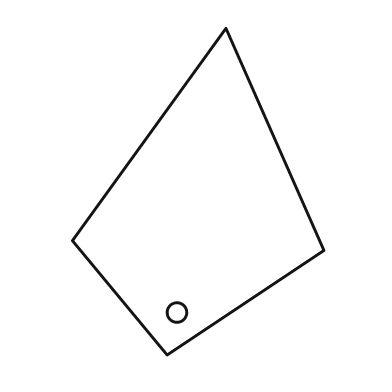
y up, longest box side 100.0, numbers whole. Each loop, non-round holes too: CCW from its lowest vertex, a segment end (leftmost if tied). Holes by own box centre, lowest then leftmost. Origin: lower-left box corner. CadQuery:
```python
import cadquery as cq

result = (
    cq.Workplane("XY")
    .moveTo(29.0, 0.0)
    .lineTo(77.0, 32.0)
    .lineTo(47.0, 100.0)
    .lineTo(0.0, 35.0)
    .close()
    .moveTo(32.0, 13.0)
    .circle(3.0)
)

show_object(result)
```